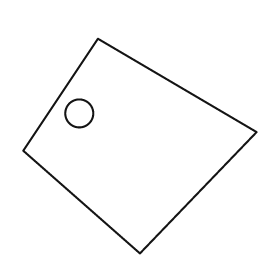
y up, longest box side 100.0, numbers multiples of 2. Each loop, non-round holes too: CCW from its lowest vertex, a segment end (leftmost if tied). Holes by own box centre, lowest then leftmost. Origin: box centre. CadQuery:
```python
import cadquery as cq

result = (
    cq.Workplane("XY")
    .moveTo(0.0, -46.0)
    .lineTo(50.0, 6.0)
    .lineTo(-18.0, 46.0)
    .lineTo(-50.0, -2.0)
    .close()
    .moveTo(-26.0, 14.0)
    .circle(6.0)
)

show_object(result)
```